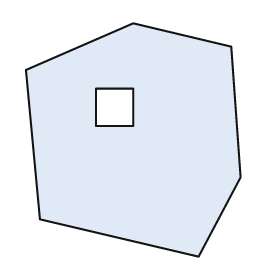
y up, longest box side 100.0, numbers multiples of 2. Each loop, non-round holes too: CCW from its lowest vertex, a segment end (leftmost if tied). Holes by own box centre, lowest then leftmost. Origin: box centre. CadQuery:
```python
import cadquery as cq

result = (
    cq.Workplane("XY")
    .moveTo(28.0, -50.0)
    .lineTo(46.0, -16.0)
    .lineTo(42.0, 40.0)
    .lineTo(0.0, 50.0)
    .lineTo(-46.0, 30.0)
    .lineTo(-40.0, -34.0)
    .close()
    .moveTo(-16.0, 6.0)
    .lineTo(0.0, 6.0)
    .lineTo(0.0, 22.0)
    .lineTo(-16.0, 22.0)
    .close()
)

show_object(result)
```